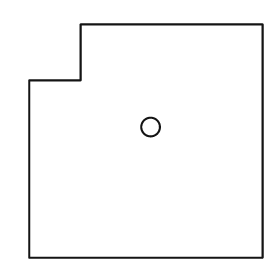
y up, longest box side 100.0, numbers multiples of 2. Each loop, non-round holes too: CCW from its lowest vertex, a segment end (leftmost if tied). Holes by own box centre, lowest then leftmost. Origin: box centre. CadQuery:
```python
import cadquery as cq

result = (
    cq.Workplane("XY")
    .moveTo(-50.0, -50.0)
    .lineTo(50.0, -50.0)
    .lineTo(50.0, 50.0)
    .lineTo(-28.0, 50.0)
    .lineTo(-28.0, 26.0)
    .lineTo(-50.0, 26.0)
    .close()
    .moveTo(2.0, 6.0)
    .circle(4.0)
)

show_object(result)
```